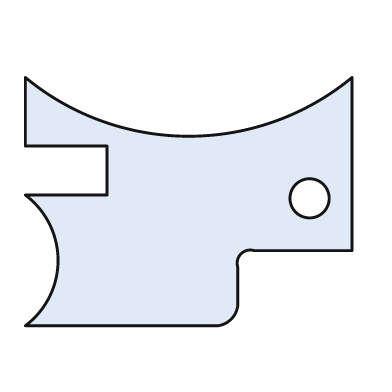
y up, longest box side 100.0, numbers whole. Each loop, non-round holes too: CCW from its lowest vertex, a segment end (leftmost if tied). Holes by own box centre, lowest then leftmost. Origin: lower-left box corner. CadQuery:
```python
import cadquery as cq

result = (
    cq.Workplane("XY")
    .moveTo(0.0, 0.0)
    .lineTo(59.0, 0.0)
    .threePointArc((63.0, 2.0), (65.0, 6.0))
    .lineTo(65.0, 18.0)
    .threePointArc((66.0, 22.0), (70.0, 23.0))
    .lineTo(100.0, 23.0)
    .lineTo(100.0, 76.0)
    .threePointArc((50.0, 58.0), (0.0, 76.0))
    .lineTo(0.0, 55.0)
    .lineTo(25.0, 55.0)
    .lineTo(25.0, 40.0)
    .lineTo(0.0, 40.0)
    .threePointArc((10.0, 20.0), (0.0, 0.0))
    .close()
    .moveTo(87.0, 39.0)
    .circle(6.0)
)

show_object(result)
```